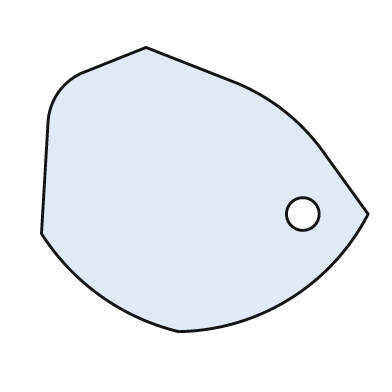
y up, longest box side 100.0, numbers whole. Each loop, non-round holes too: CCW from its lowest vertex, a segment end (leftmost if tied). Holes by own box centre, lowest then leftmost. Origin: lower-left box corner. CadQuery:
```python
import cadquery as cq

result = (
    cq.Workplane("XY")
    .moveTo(42.0, 0.0)
    .threePointArc((76.0, 10.0), (100.0, 36.0))
    .lineTo(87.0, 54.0)
    .threePointArc((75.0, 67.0), (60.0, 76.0))
    .lineTo(32.0, 87.0)
    .lineTo(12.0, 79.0)
    .threePointArc((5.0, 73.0), (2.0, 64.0))
    .lineTo(0.0, 30.0)
    .threePointArc((18.0, 11.0), (42.0, 0.0))
    .close()
    .moveTo(80.0, 36.0)
    .circle(5.0)
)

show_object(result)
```